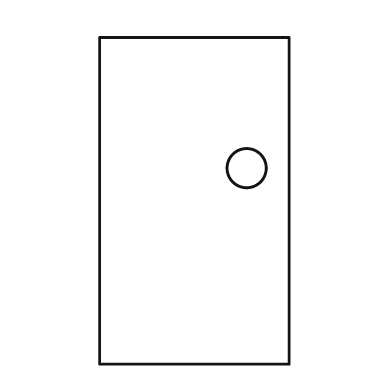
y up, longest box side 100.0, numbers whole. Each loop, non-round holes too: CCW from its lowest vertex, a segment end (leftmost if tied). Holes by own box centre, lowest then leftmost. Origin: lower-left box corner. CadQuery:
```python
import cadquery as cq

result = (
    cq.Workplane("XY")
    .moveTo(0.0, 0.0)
    .lineTo(58.0, 0.0)
    .lineTo(58.0, 100.0)
    .lineTo(0.0, 100.0)
    .close()
    .moveTo(45.0, 60.0)
    .circle(6.0)
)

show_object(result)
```